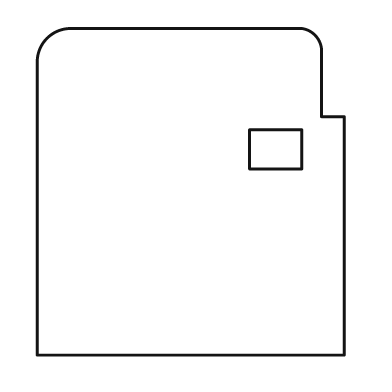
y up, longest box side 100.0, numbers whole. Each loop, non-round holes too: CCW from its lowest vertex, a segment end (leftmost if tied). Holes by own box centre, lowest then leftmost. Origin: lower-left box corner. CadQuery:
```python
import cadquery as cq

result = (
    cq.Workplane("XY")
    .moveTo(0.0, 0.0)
    .lineTo(94.0, 0.0)
    .lineTo(94.0, 73.0)
    .lineTo(87.0, 73.0)
    .lineTo(87.0, 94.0)
    .threePointArc((85.0, 98.0), (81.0, 100.0))
    .lineTo(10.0, 100.0)
    .threePointArc((3.0, 97.0), (0.0, 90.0))
    .close()
    .moveTo(65.0, 57.0)
    .lineTo(81.0, 57.0)
    .lineTo(81.0, 69.0)
    .lineTo(65.0, 69.0)
    .close()
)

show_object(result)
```